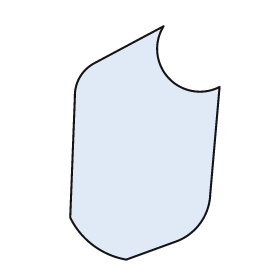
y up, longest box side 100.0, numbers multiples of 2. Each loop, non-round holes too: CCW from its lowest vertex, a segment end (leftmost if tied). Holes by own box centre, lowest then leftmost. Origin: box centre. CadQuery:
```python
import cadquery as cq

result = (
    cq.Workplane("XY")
    .moveTo(-8.0, -50.0)
    .lineTo(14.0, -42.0)
    .threePointArc((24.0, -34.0), (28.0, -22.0))
    .lineTo(32.0, 24.0)
    .threePointArc((10.0, 28.0), (8.0, 50.0))
    .lineTo(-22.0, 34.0)
    .threePointArc((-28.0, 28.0), (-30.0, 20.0))
    .lineTo(-32.0, -32.0)
    .threePointArc((-22.0, -44.0), (-8.0, -50.0))
    .close()
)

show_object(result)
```